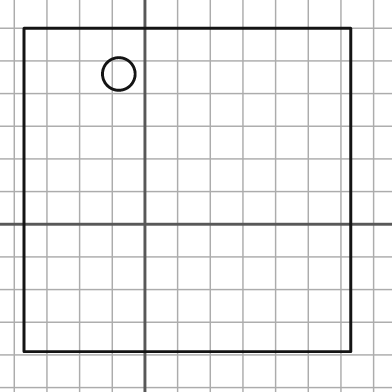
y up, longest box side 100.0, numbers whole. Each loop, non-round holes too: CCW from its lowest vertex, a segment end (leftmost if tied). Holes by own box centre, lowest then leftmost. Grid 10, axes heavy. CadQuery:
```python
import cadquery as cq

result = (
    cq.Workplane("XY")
    .moveTo(-37.0, -39.0)
    .lineTo(63.0, -39.0)
    .lineTo(63.0, 60.0)
    .lineTo(-37.0, 60.0)
    .close()
    .moveTo(-8.0, 46.0)
    .circle(5.0)
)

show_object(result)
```